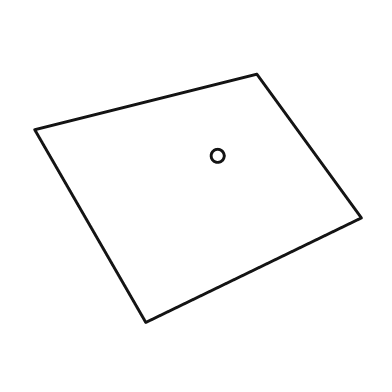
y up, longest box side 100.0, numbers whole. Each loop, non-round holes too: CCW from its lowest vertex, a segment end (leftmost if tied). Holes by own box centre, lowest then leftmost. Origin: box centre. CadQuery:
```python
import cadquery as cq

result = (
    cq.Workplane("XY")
    .moveTo(-16.0, -38.0)
    .lineTo(50.0, -6.0)
    .lineTo(18.0, 38.0)
    .lineTo(-50.0, 21.0)
    .close()
    .moveTo(6.0, 13.0)
    .circle(2.0)
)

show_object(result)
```